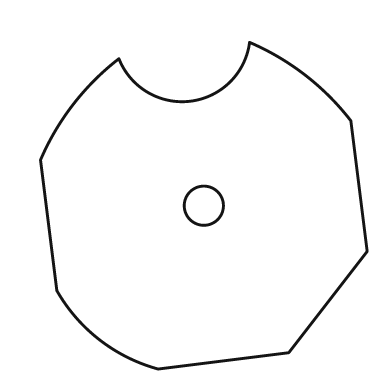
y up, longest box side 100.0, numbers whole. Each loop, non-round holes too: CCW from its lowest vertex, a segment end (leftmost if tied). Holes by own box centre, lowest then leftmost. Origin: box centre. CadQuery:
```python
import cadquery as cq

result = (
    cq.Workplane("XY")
    .moveTo(-14.0, -50.0)
    .lineTo(26.0, -45.0)
    .lineTo(50.0, -14.0)
    .lineTo(45.0, 26.0)
    .threePointArc((31.0, 40.0), (14.0, 50.0))
    .threePointArc((-4.0, 32.0), (-26.0, 45.0))
    .threePointArc((-40.0, 31.0), (-50.0, 14.0))
    .lineTo(-45.0, -26.0)
    .threePointArc((-32.0, -41.0), (-14.0, -50.0))
    .close()
    .moveTo(0.0, 0.0)
    .circle(6.0)
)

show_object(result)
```